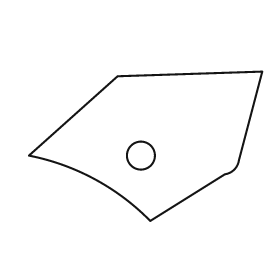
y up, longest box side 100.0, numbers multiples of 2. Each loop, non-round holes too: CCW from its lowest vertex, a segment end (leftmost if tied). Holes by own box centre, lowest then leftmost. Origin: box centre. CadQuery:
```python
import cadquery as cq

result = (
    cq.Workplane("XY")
    .moveTo(2.0, -32.0)
    .lineTo(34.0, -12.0)
    .threePointArc((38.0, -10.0), (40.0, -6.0))
    .lineTo(50.0, 32.0)
    .lineTo(-12.0, 30.0)
    .lineTo(-50.0, -4.0)
    .threePointArc((-22.0, -14.0), (2.0, -32.0))
    .close()
    .moveTo(-2.0, -4.0)
    .circle(6.0)
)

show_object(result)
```